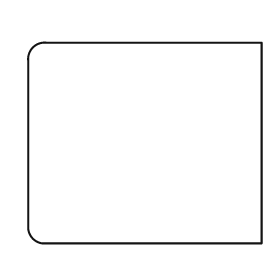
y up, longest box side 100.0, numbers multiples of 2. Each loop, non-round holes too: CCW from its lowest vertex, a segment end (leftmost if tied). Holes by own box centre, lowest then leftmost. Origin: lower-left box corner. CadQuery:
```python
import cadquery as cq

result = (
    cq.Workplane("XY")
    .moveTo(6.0, 0.0)
    .lineTo(100.0, 0.0)
    .lineTo(100.0, 86.0)
    .lineTo(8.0, 86.0)
    .threePointArc((2.0, 84.0), (0.0, 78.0))
    .lineTo(0.0, 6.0)
    .threePointArc((2.0, 2.0), (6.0, 0.0))
    .close()
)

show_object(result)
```